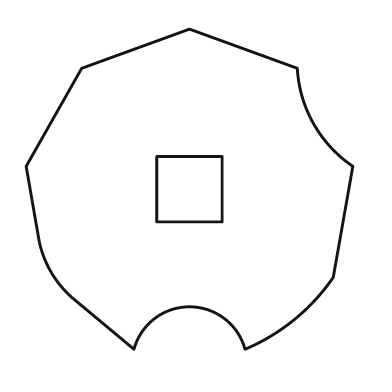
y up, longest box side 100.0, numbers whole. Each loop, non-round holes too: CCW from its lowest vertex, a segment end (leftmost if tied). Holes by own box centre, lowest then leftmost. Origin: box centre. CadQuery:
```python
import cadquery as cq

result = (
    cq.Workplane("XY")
    .moveTo(-17.0, -49.0)
    .threePointArc((0.0, -36.0), (17.0, -49.0))
    .threePointArc((32.0, -40.0), (44.0, -27.0))
    .lineTo(50.0, 7.0)
    .threePointArc((38.0, 20.0), (33.0, 37.0))
    .lineTo(0.0, 49.0)
    .lineTo(-33.0, 37.0)
    .lineTo(-50.0, 7.0)
    .lineTo(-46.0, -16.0)
    .threePointArc((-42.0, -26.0), (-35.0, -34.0))
    .close()
    .moveTo(-10.0, -10.0)
    .lineTo(10.0, -10.0)
    .lineTo(10.0, 10.0)
    .lineTo(-10.0, 10.0)
    .close()
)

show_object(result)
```